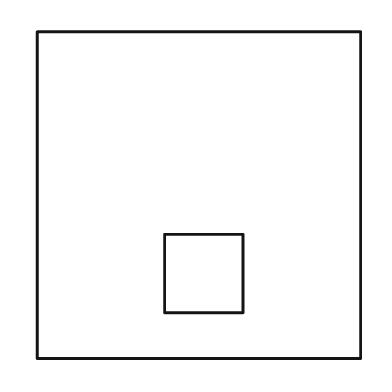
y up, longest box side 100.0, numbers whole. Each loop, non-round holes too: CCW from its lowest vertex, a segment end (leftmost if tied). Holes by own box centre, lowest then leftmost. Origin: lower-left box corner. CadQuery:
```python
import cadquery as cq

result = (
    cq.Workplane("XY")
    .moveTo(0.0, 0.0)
    .lineTo(99.0, 0.0)
    .lineTo(99.0, 100.0)
    .lineTo(0.0, 100.0)
    .close()
    .moveTo(39.0, 14.0)
    .lineTo(63.0, 14.0)
    .lineTo(63.0, 38.0)
    .lineTo(39.0, 38.0)
    .close()
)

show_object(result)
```